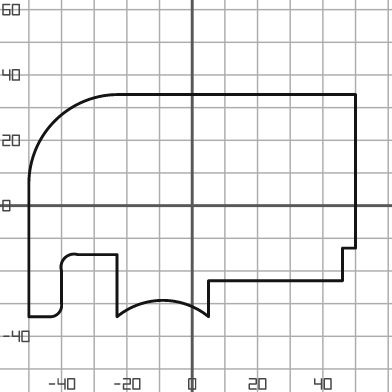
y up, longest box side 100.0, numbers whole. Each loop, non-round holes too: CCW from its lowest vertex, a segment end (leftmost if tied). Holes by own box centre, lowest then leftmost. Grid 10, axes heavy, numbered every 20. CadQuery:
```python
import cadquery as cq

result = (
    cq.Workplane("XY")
    .moveTo(-50.0, -34.0)
    .lineTo(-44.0, -34.0)
    .threePointArc((-41.0, -33.0), (-40.0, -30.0))
    .lineTo(-40.0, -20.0)
    .threePointArc((-39.0, -16.0), (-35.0, -15.0))
    .lineTo(-23.0, -15.0)
    .lineTo(-23.0, -34.0)
    .threePointArc((-9.0, -29.0), (5.0, -34.0))
    .lineTo(5.0, -23.0)
    .lineTo(46.0, -23.0)
    .lineTo(46.0, -13.0)
    .lineTo(50.0, -13.0)
    .lineTo(50.0, 34.0)
    .lineTo(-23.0, 34.0)
    .threePointArc((-42.0, 26.0), (-50.0, 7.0))
    .close()
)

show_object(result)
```